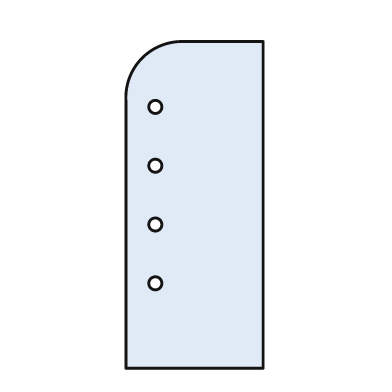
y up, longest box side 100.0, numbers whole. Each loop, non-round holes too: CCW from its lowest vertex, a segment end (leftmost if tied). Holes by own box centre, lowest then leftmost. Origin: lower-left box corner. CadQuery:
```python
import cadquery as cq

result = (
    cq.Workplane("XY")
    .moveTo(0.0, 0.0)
    .lineTo(42.0, 0.0)
    .lineTo(42.0, 100.0)
    .lineTo(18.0, 100.0)
    .threePointArc((5.0, 95.0), (0.0, 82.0))
    .close()
    .moveTo(9.0, 26.0)
    .circle(2.0)
    .moveTo(9.0, 44.0)
    .circle(2.0)
    .moveTo(9.0, 62.0)
    .circle(2.0)
    .moveTo(9.0, 80.0)
    .circle(2.0)
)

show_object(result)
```